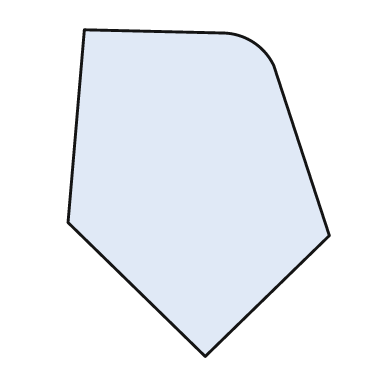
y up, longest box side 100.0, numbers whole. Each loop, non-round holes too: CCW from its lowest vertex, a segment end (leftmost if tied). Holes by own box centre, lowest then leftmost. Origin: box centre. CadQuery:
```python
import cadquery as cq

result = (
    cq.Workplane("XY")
    .moveTo(2.0, -50.0)
    .lineTo(40.0, -13.0)
    .lineTo(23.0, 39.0)
    .threePointArc((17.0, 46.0), (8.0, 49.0))
    .lineTo(-35.0, 50.0)
    .lineTo(-40.0, -9.0)
    .close()
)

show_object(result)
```